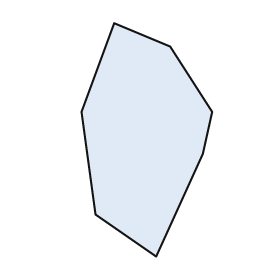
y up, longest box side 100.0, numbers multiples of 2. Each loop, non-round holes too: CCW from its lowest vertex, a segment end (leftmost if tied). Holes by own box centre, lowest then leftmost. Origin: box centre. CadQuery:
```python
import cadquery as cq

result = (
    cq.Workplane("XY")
    .moveTo(4.0, -50.0)
    .lineTo(24.0, -6.0)
    .lineTo(28.0, 12.0)
    .lineTo(10.0, 40.0)
    .lineTo(-14.0, 50.0)
    .lineTo(-28.0, 12.0)
    .lineTo(-22.0, -32.0)
    .close()
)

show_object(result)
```